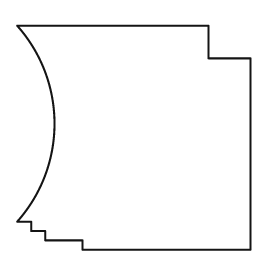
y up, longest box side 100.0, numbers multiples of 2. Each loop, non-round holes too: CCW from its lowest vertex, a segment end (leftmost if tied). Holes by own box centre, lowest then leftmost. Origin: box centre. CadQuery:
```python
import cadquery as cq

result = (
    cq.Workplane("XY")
    .moveTo(-22.0, -48.0)
    .lineTo(50.0, -48.0)
    .lineTo(50.0, 34.0)
    .lineTo(32.0, 34.0)
    .lineTo(32.0, 48.0)
    .lineTo(-50.0, 48.0)
    .threePointArc((-34.0, 6.0), (-50.0, -36.0))
    .lineTo(-44.0, -36.0)
    .lineTo(-44.0, -40.0)
    .lineTo(-38.0, -40.0)
    .lineTo(-38.0, -44.0)
    .lineTo(-22.0, -44.0)
    .close()
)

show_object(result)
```